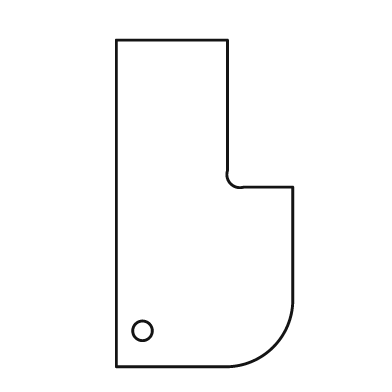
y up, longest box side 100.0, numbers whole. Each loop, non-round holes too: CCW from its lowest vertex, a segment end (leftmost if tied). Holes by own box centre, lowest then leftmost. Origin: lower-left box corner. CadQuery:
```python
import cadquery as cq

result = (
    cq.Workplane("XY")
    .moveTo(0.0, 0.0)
    .lineTo(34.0, 0.0)
    .threePointArc((48.0, 6.0), (54.0, 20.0))
    .lineTo(54.0, 55.0)
    .lineTo(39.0, 55.0)
    .threePointArc((35.0, 56.0), (34.0, 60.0))
    .lineTo(34.0, 100.0)
    .lineTo(0.0, 100.0)
    .close()
    .moveTo(8.0, 11.0)
    .circle(3.0)
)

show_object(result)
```